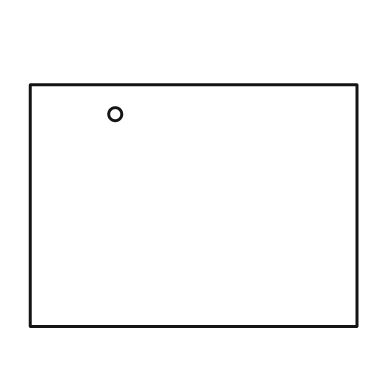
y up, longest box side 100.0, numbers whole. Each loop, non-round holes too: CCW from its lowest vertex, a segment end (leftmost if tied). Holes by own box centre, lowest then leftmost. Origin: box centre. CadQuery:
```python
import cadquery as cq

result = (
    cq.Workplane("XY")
    .moveTo(-50.0, -37.0)
    .lineTo(50.0, -37.0)
    .lineTo(50.0, 37.0)
    .lineTo(-50.0, 37.0)
    .close()
    .moveTo(-24.0, 28.0)
    .circle(2.0)
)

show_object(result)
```